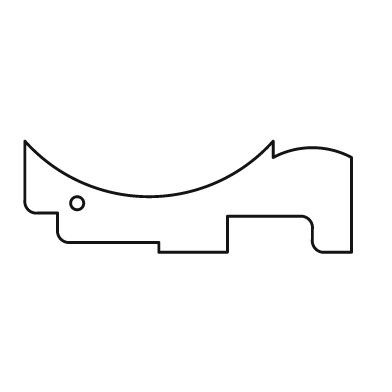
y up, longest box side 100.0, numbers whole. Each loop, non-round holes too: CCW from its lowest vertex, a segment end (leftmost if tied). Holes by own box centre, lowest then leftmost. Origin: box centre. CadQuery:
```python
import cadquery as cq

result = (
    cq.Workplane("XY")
    .moveTo(-9.0, -17.0)
    .lineTo(12.0, -17.0)
    .lineTo(12.0, -6.0)
    .lineTo(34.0, -6.0)
    .threePointArc((37.0, -7.0), (38.0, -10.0))
    .lineTo(38.0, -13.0)
    .threePointArc((39.0, -16.0), (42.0, -17.0))
    .lineTo(50.0, -17.0)
    .lineTo(50.0, 12.0)
    .threePointArc((38.0, 15.0), (26.0, 12.0))
    .lineTo(26.0, 17.0)
    .threePointArc((-12.0, 0.0), (-50.0, 17.0))
    .lineTo(-50.0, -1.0)
    .threePointArc((-49.0, -4.0), (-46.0, -5.0))
    .lineTo(-40.0, -5.0)
    .lineTo(-40.0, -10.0)
    .threePointArc((-39.0, -13.0), (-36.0, -14.0))
    .lineTo(-9.0, -14.0)
    .close()
    .moveTo(-34.0, -2.0)
    .circle(2.0)
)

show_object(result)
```